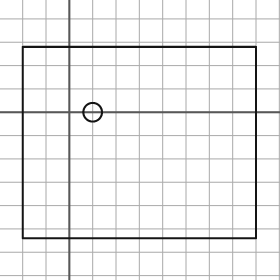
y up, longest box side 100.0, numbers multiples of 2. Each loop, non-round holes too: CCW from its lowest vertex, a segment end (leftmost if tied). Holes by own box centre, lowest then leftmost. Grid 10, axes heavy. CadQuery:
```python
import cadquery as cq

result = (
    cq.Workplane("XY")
    .moveTo(-20.0, -54.0)
    .lineTo(80.0, -54.0)
    .lineTo(80.0, 28.0)
    .lineTo(-20.0, 28.0)
    .close()
    .moveTo(10.0, 0.0)
    .circle(4.0)
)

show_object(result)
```